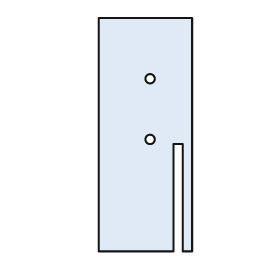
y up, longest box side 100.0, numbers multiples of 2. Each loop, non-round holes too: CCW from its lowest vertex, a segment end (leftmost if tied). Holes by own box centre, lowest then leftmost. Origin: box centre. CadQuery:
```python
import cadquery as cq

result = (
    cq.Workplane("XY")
    .moveTo(-20.0, -50.0)
    .lineTo(12.0, -50.0)
    .lineTo(12.0, -4.0)
    .lineTo(16.0, -4.0)
    .lineTo(16.0, -50.0)
    .lineTo(20.0, -50.0)
    .lineTo(20.0, 50.0)
    .lineTo(-20.0, 50.0)
    .close()
    .moveTo(2.0, -2.0)
    .circle(2.0)
    .moveTo(2.0, 24.0)
    .circle(2.0)
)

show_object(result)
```